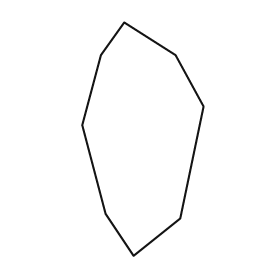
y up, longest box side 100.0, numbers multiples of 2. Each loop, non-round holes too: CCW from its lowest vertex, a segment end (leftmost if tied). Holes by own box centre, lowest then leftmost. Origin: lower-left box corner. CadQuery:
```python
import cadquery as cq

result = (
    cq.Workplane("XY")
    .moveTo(22.0, 0.0)
    .lineTo(42.0, 16.0)
    .lineTo(52.0, 64.0)
    .lineTo(40.0, 86.0)
    .lineTo(18.0, 100.0)
    .lineTo(8.0, 86.0)
    .lineTo(0.0, 56.0)
    .lineTo(10.0, 18.0)
    .close()
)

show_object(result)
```